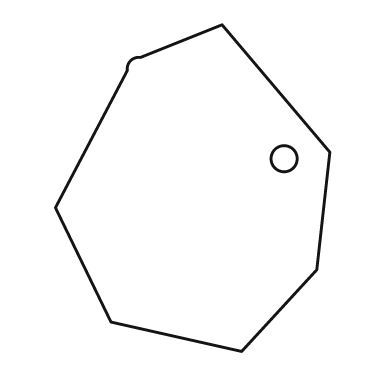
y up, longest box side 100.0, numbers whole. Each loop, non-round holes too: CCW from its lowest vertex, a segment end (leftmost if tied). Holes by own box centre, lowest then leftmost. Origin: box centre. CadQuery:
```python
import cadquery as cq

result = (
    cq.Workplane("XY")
    .moveTo(15.0, -50.0)
    .lineTo(38.0, -25.0)
    .lineTo(42.0, 11.0)
    .lineTo(9.0, 50.0)
    .lineTo(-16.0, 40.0)
    .threePointArc((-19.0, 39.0), (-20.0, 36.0))
    .lineTo(-42.0, -6.0)
    .lineTo(-25.0, -41.0)
    .close()
    .moveTo(28.0, 9.0)
    .circle(4.0)
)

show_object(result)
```